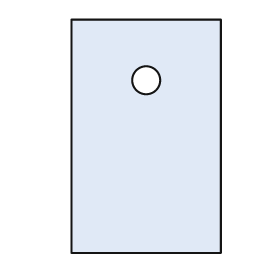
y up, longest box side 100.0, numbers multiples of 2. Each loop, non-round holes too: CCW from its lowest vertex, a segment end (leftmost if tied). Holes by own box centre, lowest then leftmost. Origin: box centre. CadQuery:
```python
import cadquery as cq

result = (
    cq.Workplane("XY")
    .moveTo(-32.0, -50.0)
    .lineTo(32.0, -50.0)
    .lineTo(32.0, 50.0)
    .lineTo(-32.0, 50.0)
    .close()
    .moveTo(0.0, 24.0)
    .circle(6.0)
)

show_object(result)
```